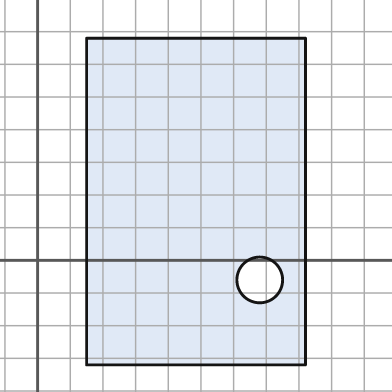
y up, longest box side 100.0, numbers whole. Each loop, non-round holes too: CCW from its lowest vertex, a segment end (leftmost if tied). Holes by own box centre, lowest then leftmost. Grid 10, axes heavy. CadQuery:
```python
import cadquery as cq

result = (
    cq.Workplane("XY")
    .moveTo(15.0, -32.0)
    .lineTo(82.0, -32.0)
    .lineTo(82.0, 68.0)
    .lineTo(15.0, 68.0)
    .close()
    .moveTo(68.0, -6.0)
    .circle(7.0)
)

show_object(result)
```